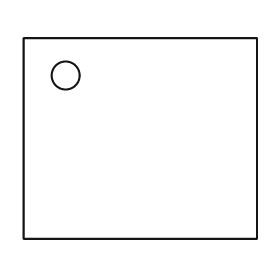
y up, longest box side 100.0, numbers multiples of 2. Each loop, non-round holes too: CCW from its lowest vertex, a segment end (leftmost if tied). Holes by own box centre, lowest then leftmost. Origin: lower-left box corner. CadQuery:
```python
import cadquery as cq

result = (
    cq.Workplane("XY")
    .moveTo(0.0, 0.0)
    .lineTo(100.0, 0.0)
    .lineTo(100.0, 86.0)
    .lineTo(0.0, 86.0)
    .close()
    .moveTo(18.0, 70.0)
    .circle(6.0)
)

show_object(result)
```